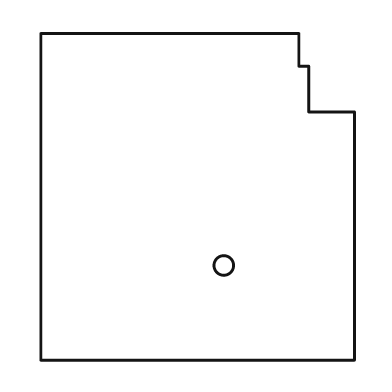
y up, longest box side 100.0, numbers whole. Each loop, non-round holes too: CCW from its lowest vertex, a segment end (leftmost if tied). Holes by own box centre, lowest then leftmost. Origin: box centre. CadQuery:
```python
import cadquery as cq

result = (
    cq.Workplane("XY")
    .moveTo(-48.0, -50.0)
    .lineTo(48.0, -50.0)
    .lineTo(48.0, 26.0)
    .lineTo(34.0, 26.0)
    .lineTo(34.0, 40.0)
    .lineTo(31.0, 40.0)
    .lineTo(31.0, 50.0)
    .lineTo(-48.0, 50.0)
    .close()
    .moveTo(8.0, -21.0)
    .circle(3.0)
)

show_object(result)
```